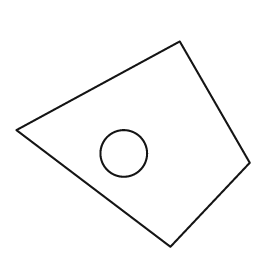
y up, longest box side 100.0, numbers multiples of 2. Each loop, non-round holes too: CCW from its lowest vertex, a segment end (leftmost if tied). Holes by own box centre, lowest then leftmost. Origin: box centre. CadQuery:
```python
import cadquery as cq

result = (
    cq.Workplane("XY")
    .moveTo(16.0, -44.0)
    .lineTo(50.0, -8.0)
    .lineTo(20.0, 44.0)
    .lineTo(-50.0, 6.0)
    .close()
    .moveTo(-4.0, -4.0)
    .circle(10.0)
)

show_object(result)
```